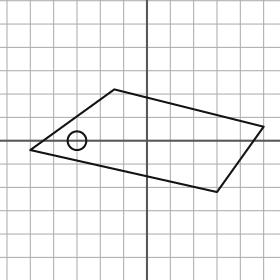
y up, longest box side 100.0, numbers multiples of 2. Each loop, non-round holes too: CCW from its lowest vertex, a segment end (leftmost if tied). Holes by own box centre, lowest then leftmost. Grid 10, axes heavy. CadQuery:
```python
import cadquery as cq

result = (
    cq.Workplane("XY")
    .moveTo(30.0, -22.0)
    .lineTo(50.0, 6.0)
    .lineTo(-14.0, 22.0)
    .lineTo(-50.0, -4.0)
    .close()
    .moveTo(-30.0, 0.0)
    .circle(4.0)
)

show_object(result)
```